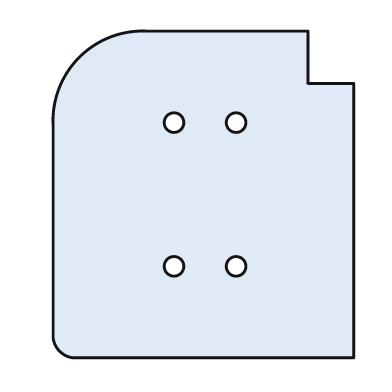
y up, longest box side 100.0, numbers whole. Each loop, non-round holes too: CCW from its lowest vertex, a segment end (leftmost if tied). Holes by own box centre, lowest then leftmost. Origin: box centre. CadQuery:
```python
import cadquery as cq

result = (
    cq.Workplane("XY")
    .moveTo(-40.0, -50.0)
    .lineTo(46.0, -50.0)
    .lineTo(46.0, 34.0)
    .lineTo(32.0, 34.0)
    .lineTo(32.0, 50.0)
    .lineTo(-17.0, 50.0)
    .threePointArc((-38.0, 42.0), (-46.0, 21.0))
    .lineTo(-46.0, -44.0)
    .threePointArc((-44.0, -48.0), (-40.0, -50.0))
    .close()
    .moveTo(-9.0, -22.0)
    .circle(3.0)
    .moveTo(10.0, -22.0)
    .circle(3.0)
    .moveTo(-9.0, 22.0)
    .circle(3.0)
    .moveTo(10.0, 22.0)
    .circle(3.0)
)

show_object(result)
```